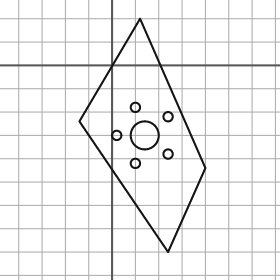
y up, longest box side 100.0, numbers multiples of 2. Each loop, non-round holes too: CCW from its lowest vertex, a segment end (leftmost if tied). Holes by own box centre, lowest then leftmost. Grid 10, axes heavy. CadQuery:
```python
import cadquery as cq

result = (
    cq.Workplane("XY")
    .moveTo(24.0, -80.0)
    .lineTo(40.0, -44.0)
    .lineTo(12.0, 20.0)
    .lineTo(-14.0, -24.0)
    .close()
    .moveTo(10.0, -42.0)
    .circle(2.0)
    .moveTo(24.0, -38.0)
    .circle(2.0)
    .moveTo(2.0, -30.0)
    .circle(2.0)
    .moveTo(14.0, -30.0)
    .circle(6.0)
    .moveTo(24.0, -22.0)
    .circle(2.0)
    .moveTo(10.0, -18.0)
    .circle(2.0)
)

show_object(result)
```